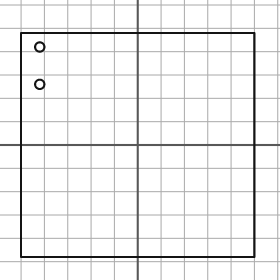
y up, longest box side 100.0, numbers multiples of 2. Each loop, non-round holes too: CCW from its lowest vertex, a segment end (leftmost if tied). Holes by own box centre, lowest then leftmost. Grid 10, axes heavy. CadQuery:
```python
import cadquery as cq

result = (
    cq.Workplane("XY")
    .moveTo(-50.0, -48.0)
    .lineTo(50.0, -48.0)
    .lineTo(50.0, 48.0)
    .lineTo(-50.0, 48.0)
    .close()
    .moveTo(-42.0, 26.0)
    .circle(2.0)
    .moveTo(-42.0, 42.0)
    .circle(2.0)
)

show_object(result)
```